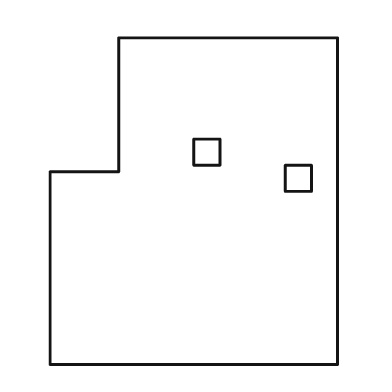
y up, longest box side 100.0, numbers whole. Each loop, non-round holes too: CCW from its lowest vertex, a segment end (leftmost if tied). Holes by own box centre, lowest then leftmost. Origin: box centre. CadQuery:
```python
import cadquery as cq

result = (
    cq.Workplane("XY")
    .moveTo(-44.0, -50.0)
    .lineTo(44.0, -50.0)
    .lineTo(44.0, 50.0)
    .lineTo(-23.0, 50.0)
    .lineTo(-23.0, 9.0)
    .lineTo(-44.0, 9.0)
    .close()
    .moveTo(28.0, 3.0)
    .lineTo(36.0, 3.0)
    .lineTo(36.0, 11.0)
    .lineTo(28.0, 11.0)
    .close()
    .moveTo(0.0, 11.0)
    .lineTo(8.0, 11.0)
    .lineTo(8.0, 19.0)
    .lineTo(0.0, 19.0)
    .close()
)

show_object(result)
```